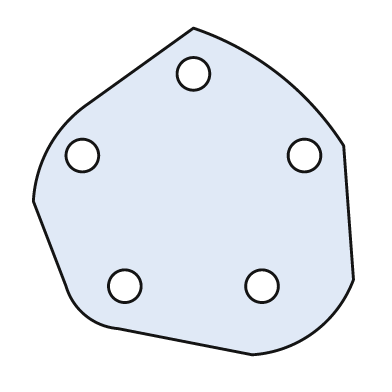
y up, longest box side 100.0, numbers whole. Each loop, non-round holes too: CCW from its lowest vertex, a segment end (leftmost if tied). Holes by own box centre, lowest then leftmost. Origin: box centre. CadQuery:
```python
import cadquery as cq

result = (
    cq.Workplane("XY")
    .moveTo(18.0, -50.0)
    .threePointArc((37.0, -43.0), (49.0, -27.0))
    .lineTo(46.0, 14.0)
    .threePointArc((26.0, 36.0), (0.0, 50.0))
    .lineTo(-32.0, 27.0)
    .threePointArc((-44.0, 14.0), (-49.0, -3.0))
    .lineTo(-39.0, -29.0)
    .threePointArc((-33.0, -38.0), (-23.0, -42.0))
    .close()
    .moveTo(-21.0, -29.0)
    .circle(5.0)
    .moveTo(21.0, -29.0)
    .circle(5.0)
    .moveTo(-34.0, 11.0)
    .circle(5.0)
    .moveTo(34.0, 11.0)
    .circle(5.0)
    .moveTo(0.0, 36.0)
    .circle(5.0)
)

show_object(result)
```